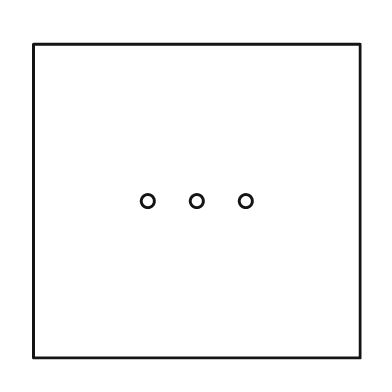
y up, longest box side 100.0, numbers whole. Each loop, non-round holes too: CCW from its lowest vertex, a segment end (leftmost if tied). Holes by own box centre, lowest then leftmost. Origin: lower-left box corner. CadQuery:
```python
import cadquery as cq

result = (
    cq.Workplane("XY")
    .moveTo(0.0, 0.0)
    .lineTo(100.0, 0.0)
    .lineTo(100.0, 96.0)
    .lineTo(0.0, 96.0)
    .close()
    .moveTo(35.0, 48.0)
    .circle(2.0)
    .moveTo(50.0, 48.0)
    .circle(2.0)
    .moveTo(65.0, 48.0)
    .circle(2.0)
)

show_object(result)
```